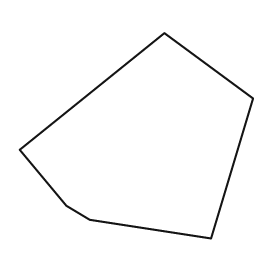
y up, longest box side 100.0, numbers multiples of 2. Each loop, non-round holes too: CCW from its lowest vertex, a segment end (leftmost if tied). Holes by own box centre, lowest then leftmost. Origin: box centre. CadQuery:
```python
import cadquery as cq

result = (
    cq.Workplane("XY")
    .moveTo(32.0, -44.0)
    .lineTo(50.0, 16.0)
    .lineTo(12.0, 44.0)
    .lineTo(-50.0, -6.0)
    .lineTo(-30.0, -30.0)
    .lineTo(-20.0, -36.0)
    .close()
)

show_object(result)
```